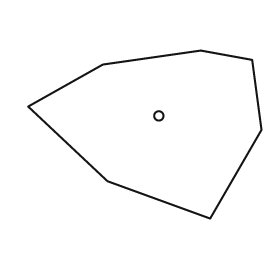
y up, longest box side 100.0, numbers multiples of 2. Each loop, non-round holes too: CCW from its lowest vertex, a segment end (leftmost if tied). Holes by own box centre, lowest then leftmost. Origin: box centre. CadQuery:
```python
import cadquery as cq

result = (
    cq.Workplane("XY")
    .moveTo(28.0, -36.0)
    .lineTo(50.0, 2.0)
    .lineTo(46.0, 32.0)
    .lineTo(24.0, 36.0)
    .lineTo(-18.0, 30.0)
    .lineTo(-50.0, 12.0)
    .lineTo(-16.0, -20.0)
    .close()
    .moveTo(6.0, 8.0)
    .circle(2.0)
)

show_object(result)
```